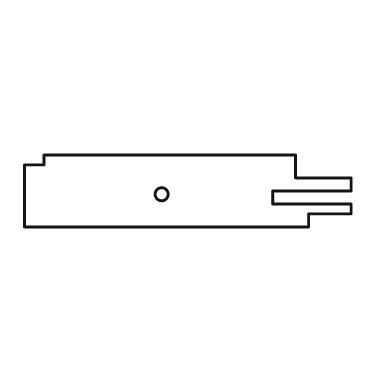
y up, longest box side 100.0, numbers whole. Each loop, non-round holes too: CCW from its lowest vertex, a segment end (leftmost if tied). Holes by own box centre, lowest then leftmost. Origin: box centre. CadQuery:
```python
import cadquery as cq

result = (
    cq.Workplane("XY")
    .moveTo(-50.0, -11.0)
    .lineTo(37.0, -11.0)
    .lineTo(37.0, -7.0)
    .lineTo(50.0, -7.0)
    .lineTo(50.0, -4.0)
    .lineTo(26.0, -4.0)
    .lineTo(26.0, 0.0)
    .lineTo(50.0, 0.0)
    .lineTo(50.0, 4.0)
    .lineTo(33.0, 4.0)
    .lineTo(33.0, 11.0)
    .lineTo(-44.0, 11.0)
    .lineTo(-44.0, 8.0)
    .lineTo(-50.0, 8.0)
    .close()
    .moveTo(-8.0, -1.0)
    .circle(2.0)
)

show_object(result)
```